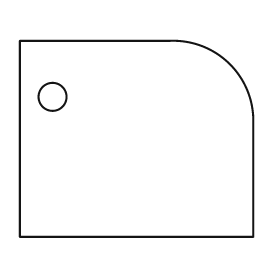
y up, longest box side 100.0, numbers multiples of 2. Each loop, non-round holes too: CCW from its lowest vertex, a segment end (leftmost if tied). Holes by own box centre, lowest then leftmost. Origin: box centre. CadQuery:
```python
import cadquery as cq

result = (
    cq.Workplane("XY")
    .moveTo(-50.0, -42.0)
    .lineTo(50.0, -42.0)
    .lineTo(50.0, 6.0)
    .threePointArc((40.0, 32.0), (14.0, 42.0))
    .lineTo(-50.0, 42.0)
    .close()
    .moveTo(-36.0, 18.0)
    .circle(6.0)
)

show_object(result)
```